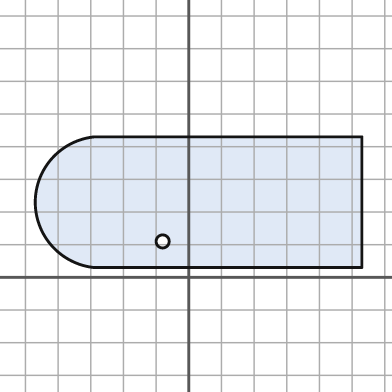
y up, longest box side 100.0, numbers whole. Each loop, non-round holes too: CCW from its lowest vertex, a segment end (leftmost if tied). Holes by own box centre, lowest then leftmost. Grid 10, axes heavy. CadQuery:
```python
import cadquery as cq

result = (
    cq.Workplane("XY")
    .moveTo(-29.0, 3.0)
    .lineTo(53.0, 3.0)
    .lineTo(53.0, 43.0)
    .lineTo(-29.0, 43.0)
    .threePointArc((-47.0, 23.0), (-29.0, 3.0))
    .close()
    .moveTo(-8.0, 11.0)
    .circle(2.0)
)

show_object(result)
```